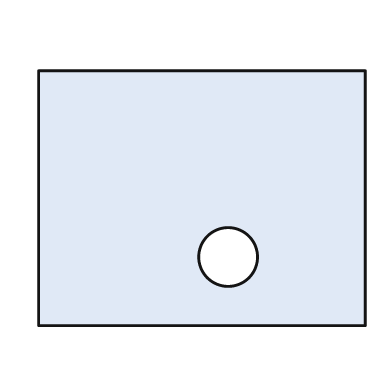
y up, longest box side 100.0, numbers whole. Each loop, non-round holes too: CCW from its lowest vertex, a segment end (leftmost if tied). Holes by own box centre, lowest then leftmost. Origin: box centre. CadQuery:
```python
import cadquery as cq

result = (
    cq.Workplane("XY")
    .moveTo(-50.0, -39.0)
    .lineTo(50.0, -39.0)
    .lineTo(50.0, 39.0)
    .lineTo(-50.0, 39.0)
    .close()
    .moveTo(8.0, -18.0)
    .circle(9.0)
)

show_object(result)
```